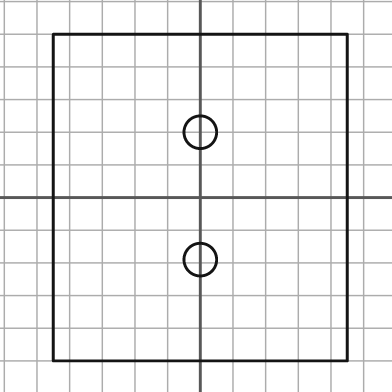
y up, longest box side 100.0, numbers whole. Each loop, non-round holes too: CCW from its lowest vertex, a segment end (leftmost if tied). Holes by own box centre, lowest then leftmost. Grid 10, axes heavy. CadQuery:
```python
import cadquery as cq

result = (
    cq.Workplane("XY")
    .moveTo(-45.0, -50.0)
    .lineTo(45.0, -50.0)
    .lineTo(45.0, 50.0)
    .lineTo(-45.0, 50.0)
    .close()
    .moveTo(0.0, -19.0)
    .circle(5.0)
    .moveTo(0.0, 20.0)
    .circle(5.0)
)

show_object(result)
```